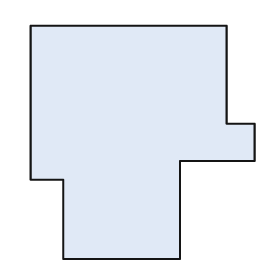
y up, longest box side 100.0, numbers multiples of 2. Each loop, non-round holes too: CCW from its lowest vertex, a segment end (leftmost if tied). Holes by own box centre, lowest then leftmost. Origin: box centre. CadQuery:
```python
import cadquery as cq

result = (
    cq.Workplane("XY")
    .moveTo(-34.0, -50.0)
    .lineTo(16.0, -50.0)
    .lineTo(16.0, -8.0)
    .lineTo(48.0, -8.0)
    .lineTo(48.0, 8.0)
    .lineTo(36.0, 8.0)
    .lineTo(36.0, 50.0)
    .lineTo(-48.0, 50.0)
    .lineTo(-48.0, -16.0)
    .lineTo(-34.0, -16.0)
    .close()
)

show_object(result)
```